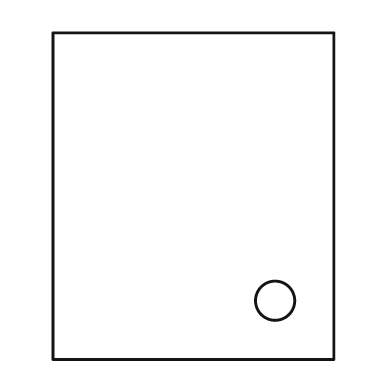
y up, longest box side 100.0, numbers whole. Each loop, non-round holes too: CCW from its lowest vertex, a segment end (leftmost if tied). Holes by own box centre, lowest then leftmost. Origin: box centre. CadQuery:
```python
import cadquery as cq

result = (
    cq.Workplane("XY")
    .moveTo(-43.0, -50.0)
    .lineTo(43.0, -50.0)
    .lineTo(43.0, 50.0)
    .lineTo(-43.0, 50.0)
    .close()
    .moveTo(25.0, -32.0)
    .circle(6.0)
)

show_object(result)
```